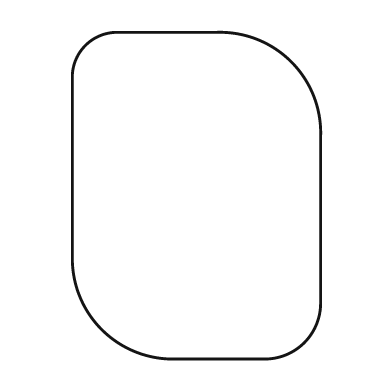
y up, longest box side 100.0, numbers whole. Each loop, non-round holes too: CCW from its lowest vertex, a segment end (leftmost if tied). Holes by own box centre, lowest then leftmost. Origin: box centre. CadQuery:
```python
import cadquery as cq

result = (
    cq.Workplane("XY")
    .moveTo(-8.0, -50.0)
    .lineTo(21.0, -50.0)
    .threePointArc((33.0, -45.0), (38.0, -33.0))
    .lineTo(38.0, 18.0)
    .threePointArc((29.0, 41.0), (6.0, 50.0))
    .lineTo(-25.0, 50.0)
    .threePointArc((-34.0, 46.0), (-38.0, 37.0))
    .lineTo(-38.0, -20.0)
    .threePointArc((-29.0, -41.0), (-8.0, -50.0))
    .close()
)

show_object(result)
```